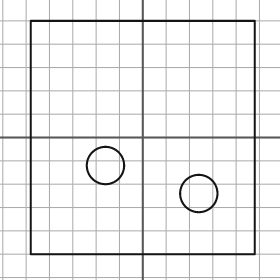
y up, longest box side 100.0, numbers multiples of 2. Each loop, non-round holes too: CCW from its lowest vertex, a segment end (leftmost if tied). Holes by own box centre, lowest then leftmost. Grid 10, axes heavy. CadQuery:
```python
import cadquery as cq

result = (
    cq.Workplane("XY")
    .moveTo(-48.0, -50.0)
    .lineTo(48.0, -50.0)
    .lineTo(48.0, 50.0)
    .lineTo(-48.0, 50.0)
    .close()
    .moveTo(24.0, -24.0)
    .circle(8.0)
    .moveTo(-16.0, -12.0)
    .circle(8.0)
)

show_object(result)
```